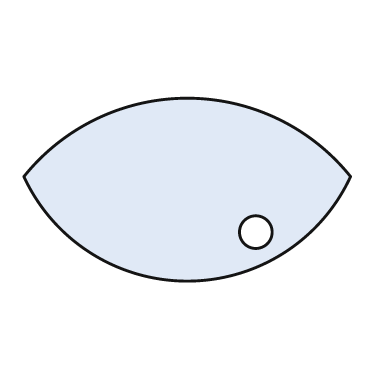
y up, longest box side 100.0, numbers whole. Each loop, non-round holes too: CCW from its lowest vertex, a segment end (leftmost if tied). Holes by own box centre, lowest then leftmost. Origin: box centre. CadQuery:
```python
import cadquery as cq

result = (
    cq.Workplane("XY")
    .moveTo(-50.0, 4.0)
    .threePointArc((0.0, -28.0), (50.0, 4.0))
    .threePointArc((0.0, 28.0), (-50.0, 4.0))
    .close()
    .moveTo(21.0, -13.0)
    .circle(5.0)
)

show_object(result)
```